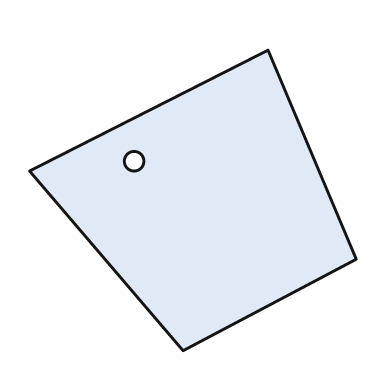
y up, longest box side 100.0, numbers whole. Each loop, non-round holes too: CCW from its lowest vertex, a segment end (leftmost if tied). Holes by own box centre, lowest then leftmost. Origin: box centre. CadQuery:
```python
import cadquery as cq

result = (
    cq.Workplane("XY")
    .moveTo(-3.0, -46.0)
    .lineTo(50.0, -18.0)
    .lineTo(23.0, 46.0)
    .lineTo(-50.0, 9.0)
    .close()
    .moveTo(-18.0, 12.0)
    .circle(3.0)
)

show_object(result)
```